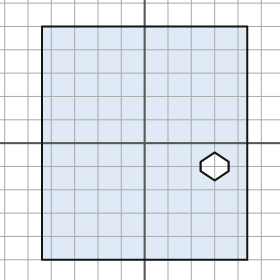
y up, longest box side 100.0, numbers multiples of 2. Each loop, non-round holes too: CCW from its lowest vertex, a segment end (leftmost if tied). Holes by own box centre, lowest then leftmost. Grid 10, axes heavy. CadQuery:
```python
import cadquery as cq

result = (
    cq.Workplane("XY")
    .moveTo(-44.0, -50.0)
    .lineTo(44.0, -50.0)
    .lineTo(44.0, 50.0)
    .lineTo(-44.0, 50.0)
    .close()
    .moveTo(30.0, -16.0)
    .lineTo(36.0, -12.0)
    .lineTo(36.0, -8.0)
    .lineTo(30.0, -4.0)
    .lineTo(24.0, -8.0)
    .lineTo(24.0, -12.0)
    .close()
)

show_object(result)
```